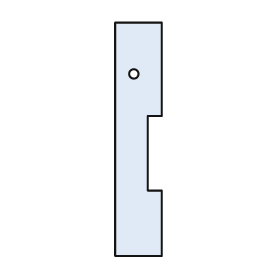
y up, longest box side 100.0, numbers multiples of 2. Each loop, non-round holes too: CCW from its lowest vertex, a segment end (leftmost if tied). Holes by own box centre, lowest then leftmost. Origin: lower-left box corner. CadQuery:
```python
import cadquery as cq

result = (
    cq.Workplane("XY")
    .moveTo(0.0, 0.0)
    .lineTo(20.0, 0.0)
    .lineTo(20.0, 28.0)
    .lineTo(14.0, 28.0)
    .lineTo(14.0, 60.0)
    .lineTo(20.0, 60.0)
    .lineTo(20.0, 100.0)
    .lineTo(0.0, 100.0)
    .close()
    .moveTo(8.0, 78.0)
    .circle(2.0)
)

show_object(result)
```